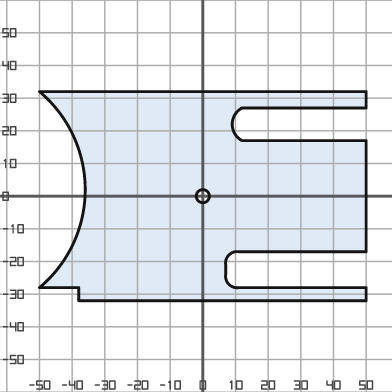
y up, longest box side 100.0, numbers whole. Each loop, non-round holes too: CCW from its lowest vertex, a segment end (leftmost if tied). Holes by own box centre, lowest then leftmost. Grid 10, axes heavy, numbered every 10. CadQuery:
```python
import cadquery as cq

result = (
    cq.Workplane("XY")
    .moveTo(-38.0, -32.0)
    .lineTo(50.0, -32.0)
    .lineTo(50.0, -28.0)
    .lineTo(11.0, -28.0)
    .threePointArc((8.0, -27.0), (7.0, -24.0))
    .lineTo(7.0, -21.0)
    .threePointArc((8.0, -18.0), (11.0, -17.0))
    .lineTo(50.0, -17.0)
    .lineTo(50.0, 17.0)
    .lineTo(12.0, 17.0)
    .threePointArc((9.0, 22.0), (12.0, 27.0))
    .lineTo(50.0, 27.0)
    .lineTo(50.0, 32.0)
    .lineTo(-50.0, 32.0)
    .threePointArc((-36.0, 2.0), (-50.0, -28.0))
    .lineTo(-38.0, -28.0)
    .close()
    .moveTo(0.0, 0.0)
    .circle(2.0)
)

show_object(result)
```